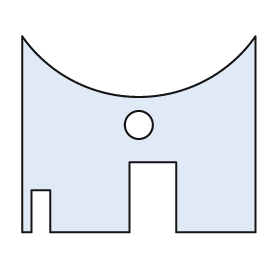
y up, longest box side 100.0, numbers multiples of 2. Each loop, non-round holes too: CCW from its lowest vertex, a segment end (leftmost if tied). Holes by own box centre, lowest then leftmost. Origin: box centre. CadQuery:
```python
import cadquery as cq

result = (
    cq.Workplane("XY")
    .moveTo(-50.0, -42.0)
    .lineTo(-46.0, -42.0)
    .lineTo(-46.0, -24.0)
    .lineTo(-38.0, -24.0)
    .lineTo(-38.0, -42.0)
    .lineTo(-4.0, -42.0)
    .lineTo(-4.0, -12.0)
    .lineTo(16.0, -12.0)
    .lineTo(16.0, -42.0)
    .lineTo(50.0, -42.0)
    .lineTo(50.0, 42.0)
    .threePointArc((0.0, 16.0), (-50.0, 42.0))
    .close()
    .moveTo(0.0, 4.0)
    .circle(6.0)
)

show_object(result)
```